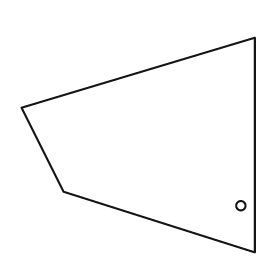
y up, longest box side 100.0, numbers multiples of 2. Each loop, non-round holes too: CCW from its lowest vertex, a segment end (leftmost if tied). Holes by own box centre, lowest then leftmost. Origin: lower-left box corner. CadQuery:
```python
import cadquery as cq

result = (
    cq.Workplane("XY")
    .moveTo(100.0, 0.0)
    .lineTo(100.0, 92.0)
    .lineTo(0.0, 62.0)
    .lineTo(18.0, 26.0)
    .close()
    .moveTo(94.0, 20.0)
    .circle(2.0)
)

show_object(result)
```